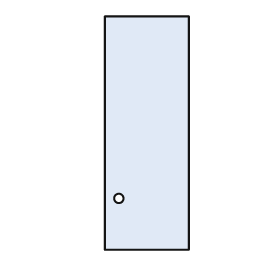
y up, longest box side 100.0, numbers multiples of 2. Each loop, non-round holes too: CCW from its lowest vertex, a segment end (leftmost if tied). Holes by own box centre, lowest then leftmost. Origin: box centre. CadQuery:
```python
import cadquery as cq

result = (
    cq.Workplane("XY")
    .moveTo(-18.0, -50.0)
    .lineTo(18.0, -50.0)
    .lineTo(18.0, 50.0)
    .lineTo(-18.0, 50.0)
    .close()
    .moveTo(-12.0, -28.0)
    .circle(2.0)
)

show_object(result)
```